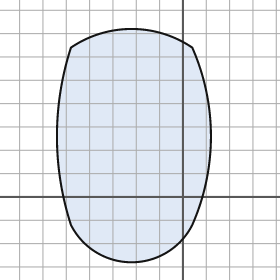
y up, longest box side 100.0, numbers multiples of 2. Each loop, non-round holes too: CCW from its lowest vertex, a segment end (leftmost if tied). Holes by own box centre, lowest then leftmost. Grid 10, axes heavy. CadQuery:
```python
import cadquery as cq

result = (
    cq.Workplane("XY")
    .moveTo(-48.0, -12.0)
    .threePointArc((-22.0, -28.0), (4.0, -12.0))
    .threePointArc((12.0, 26.0), (4.0, 64.0))
    .threePointArc((-22.0, 72.0), (-48.0, 64.0))
    .threePointArc((-54.0, 26.0), (-48.0, -12.0))
    .close()
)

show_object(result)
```